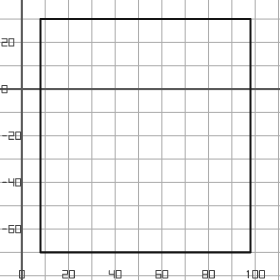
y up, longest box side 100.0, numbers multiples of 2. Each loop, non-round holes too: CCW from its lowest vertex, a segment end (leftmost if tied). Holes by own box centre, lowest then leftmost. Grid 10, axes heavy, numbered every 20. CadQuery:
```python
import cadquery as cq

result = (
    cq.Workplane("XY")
    .moveTo(8.0, -70.0)
    .lineTo(98.0, -70.0)
    .lineTo(98.0, 30.0)
    .lineTo(8.0, 30.0)
    .close()
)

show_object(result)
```